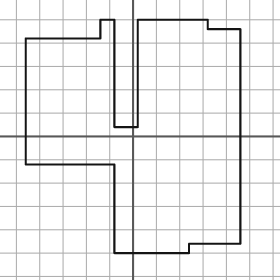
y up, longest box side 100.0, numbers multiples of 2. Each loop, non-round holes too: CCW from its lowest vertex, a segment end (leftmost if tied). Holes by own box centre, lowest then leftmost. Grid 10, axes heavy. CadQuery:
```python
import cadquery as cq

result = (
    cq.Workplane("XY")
    .moveTo(-8.0, -50.0)
    .lineTo(24.0, -50.0)
    .lineTo(24.0, -46.0)
    .lineTo(46.0, -46.0)
    .lineTo(46.0, 46.0)
    .lineTo(32.0, 46.0)
    .lineTo(32.0, 50.0)
    .lineTo(2.0, 50.0)
    .lineTo(2.0, 4.0)
    .lineTo(-8.0, 4.0)
    .lineTo(-8.0, 50.0)
    .lineTo(-14.0, 50.0)
    .lineTo(-14.0, 42.0)
    .lineTo(-46.0, 42.0)
    .lineTo(-46.0, -12.0)
    .lineTo(-8.0, -12.0)
    .close()
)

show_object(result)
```